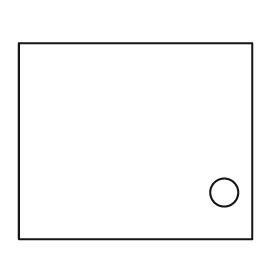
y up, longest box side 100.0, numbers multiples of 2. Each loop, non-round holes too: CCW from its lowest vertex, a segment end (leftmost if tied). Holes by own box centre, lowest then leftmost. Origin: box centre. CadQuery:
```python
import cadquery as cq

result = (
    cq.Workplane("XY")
    .moveTo(-50.0, -42.0)
    .lineTo(50.0, -42.0)
    .lineTo(50.0, 42.0)
    .lineTo(-50.0, 42.0)
    .close()
    .moveTo(38.0, -22.0)
    .circle(6.0)
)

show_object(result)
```